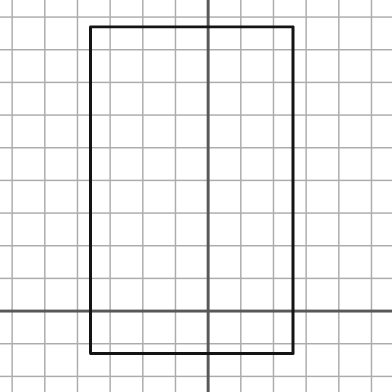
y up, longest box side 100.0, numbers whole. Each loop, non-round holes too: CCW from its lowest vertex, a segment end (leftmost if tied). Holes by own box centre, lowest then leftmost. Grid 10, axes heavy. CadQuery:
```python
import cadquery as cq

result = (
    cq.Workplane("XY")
    .moveTo(-36.0, -13.0)
    .lineTo(26.0, -13.0)
    .lineTo(26.0, 87.0)
    .lineTo(-36.0, 87.0)
    .close()
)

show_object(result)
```